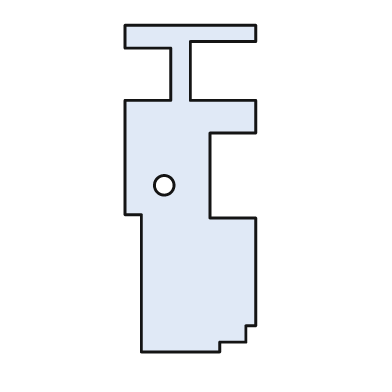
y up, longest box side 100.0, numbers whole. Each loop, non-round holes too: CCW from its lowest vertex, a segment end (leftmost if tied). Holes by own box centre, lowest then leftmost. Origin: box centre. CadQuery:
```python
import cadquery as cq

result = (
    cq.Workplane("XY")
    .moveTo(-15.0, -50.0)
    .lineTo(9.0, -50.0)
    .lineTo(9.0, -47.0)
    .lineTo(17.0, -47.0)
    .lineTo(17.0, -42.0)
    .lineTo(20.0, -42.0)
    .lineTo(20.0, -9.0)
    .lineTo(6.0, -9.0)
    .lineTo(6.0, 17.0)
    .lineTo(20.0, 17.0)
    .lineTo(20.0, 27.0)
    .lineTo(0.0, 27.0)
    .lineTo(0.0, 45.0)
    .lineTo(20.0, 45.0)
    .lineTo(20.0, 50.0)
    .lineTo(-20.0, 50.0)
    .lineTo(-20.0, 43.0)
    .lineTo(-6.0, 43.0)
    .lineTo(-6.0, 27.0)
    .lineTo(-20.0, 27.0)
    .lineTo(-20.0, -8.0)
    .lineTo(-15.0, -8.0)
    .close()
    .moveTo(-8.0, 1.0)
    .circle(3.0)
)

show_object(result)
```